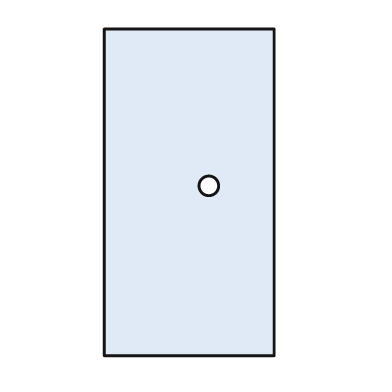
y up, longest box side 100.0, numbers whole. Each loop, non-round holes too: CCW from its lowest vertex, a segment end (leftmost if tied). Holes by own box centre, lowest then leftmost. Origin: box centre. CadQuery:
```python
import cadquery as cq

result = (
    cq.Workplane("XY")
    .moveTo(-26.0, -50.0)
    .lineTo(26.0, -50.0)
    .lineTo(26.0, 50.0)
    .lineTo(-26.0, 50.0)
    .close()
    .moveTo(6.0, 2.0)
    .circle(3.0)
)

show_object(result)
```